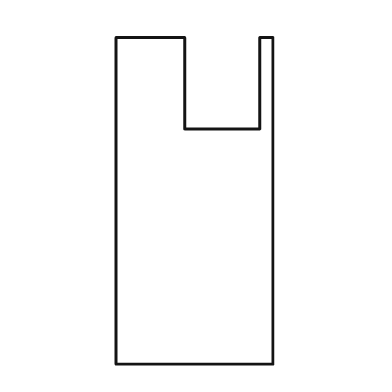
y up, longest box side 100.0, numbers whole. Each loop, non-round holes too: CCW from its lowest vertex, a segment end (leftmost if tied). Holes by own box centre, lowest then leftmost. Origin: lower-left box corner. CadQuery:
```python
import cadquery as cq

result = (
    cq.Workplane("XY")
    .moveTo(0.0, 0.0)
    .lineTo(48.0, 0.0)
    .lineTo(48.0, 100.0)
    .lineTo(44.0, 100.0)
    .lineTo(44.0, 72.0)
    .lineTo(21.0, 72.0)
    .lineTo(21.0, 100.0)
    .lineTo(0.0, 100.0)
    .close()
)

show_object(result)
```